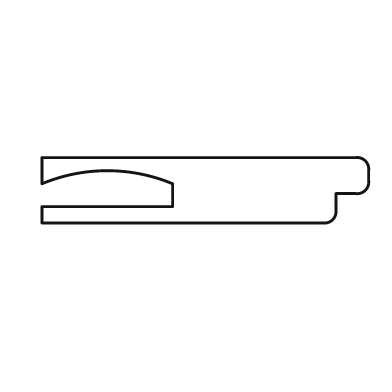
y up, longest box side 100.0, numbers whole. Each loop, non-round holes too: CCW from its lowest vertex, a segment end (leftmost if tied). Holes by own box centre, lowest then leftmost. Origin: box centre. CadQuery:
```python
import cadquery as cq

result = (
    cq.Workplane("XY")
    .moveTo(-50.0, -10.0)
    .lineTo(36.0, -10.0)
    .threePointArc((39.0, -9.0), (40.0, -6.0))
    .lineTo(40.0, -1.0)
    .lineTo(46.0, -1.0)
    .threePointArc((49.0, 0.0), (50.0, 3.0))
    .lineTo(50.0, 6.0)
    .threePointArc((49.0, 9.0), (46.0, 10.0))
    .lineTo(-50.0, 10.0)
    .lineTo(-50.0, 2.0)
    .threePointArc((-30.0, 6.0), (-10.0, 2.0))
    .lineTo(-10.0, -5.0)
    .lineTo(-50.0, -5.0)
    .close()
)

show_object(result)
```